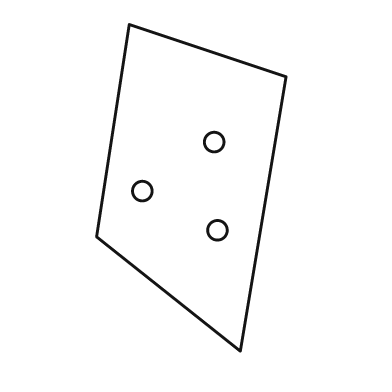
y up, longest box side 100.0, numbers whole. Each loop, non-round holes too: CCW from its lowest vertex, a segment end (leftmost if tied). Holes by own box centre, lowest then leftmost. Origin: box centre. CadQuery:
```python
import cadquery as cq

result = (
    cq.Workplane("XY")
    .moveTo(15.0, -50.0)
    .lineTo(29.0, 34.0)
    .lineTo(-19.0, 50.0)
    .lineTo(-29.0, -15.0)
    .close()
    .moveTo(8.0, -13.0)
    .circle(3.0)
    .moveTo(-15.0, -1.0)
    .circle(3.0)
    .moveTo(7.0, 14.0)
    .circle(3.0)
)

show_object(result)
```